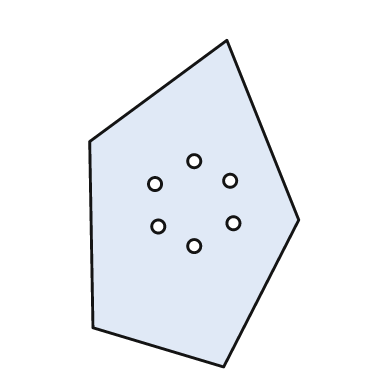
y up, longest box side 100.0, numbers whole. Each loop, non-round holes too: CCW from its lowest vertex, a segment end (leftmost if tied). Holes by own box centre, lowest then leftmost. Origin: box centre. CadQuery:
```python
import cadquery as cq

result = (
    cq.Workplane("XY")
    .moveTo(9.0, -50.0)
    .lineTo(32.0, -5.0)
    .lineTo(10.0, 50.0)
    .lineTo(-32.0, 19.0)
    .lineTo(-31.0, -38.0)
    .close()
    .moveTo(0.0, -13.0)
    .circle(2.0)
    .moveTo(-11.0, -7.0)
    .circle(2.0)
    .moveTo(12.0, -6.0)
    .circle(2.0)
    .moveTo(-12.0, 6.0)
    .circle(2.0)
    .moveTo(11.0, 7.0)
    .circle(2.0)
    .moveTo(0.0, 13.0)
    .circle(2.0)
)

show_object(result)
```